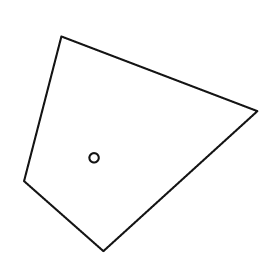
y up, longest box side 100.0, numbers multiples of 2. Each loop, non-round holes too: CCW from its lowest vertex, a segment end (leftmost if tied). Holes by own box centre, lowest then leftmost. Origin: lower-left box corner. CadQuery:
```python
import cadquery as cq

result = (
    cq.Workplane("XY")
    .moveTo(34.0, 0.0)
    .lineTo(100.0, 60.0)
    .lineTo(16.0, 92.0)
    .lineTo(0.0, 30.0)
    .close()
    .moveTo(30.0, 40.0)
    .circle(2.0)
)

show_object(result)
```